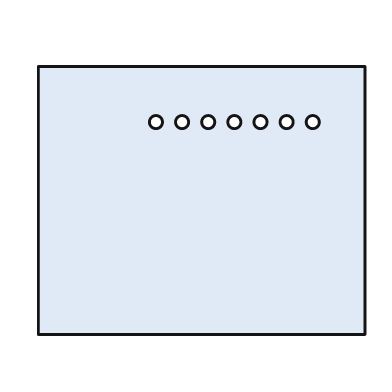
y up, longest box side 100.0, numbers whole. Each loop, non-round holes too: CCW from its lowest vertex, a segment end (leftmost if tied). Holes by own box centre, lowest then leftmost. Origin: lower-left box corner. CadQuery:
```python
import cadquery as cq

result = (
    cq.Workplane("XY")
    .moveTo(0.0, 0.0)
    .lineTo(100.0, 0.0)
    .lineTo(100.0, 82.0)
    .lineTo(0.0, 82.0)
    .close()
    .moveTo(36.0, 65.0)
    .circle(2.0)
    .moveTo(44.0, 65.0)
    .circle(2.0)
    .moveTo(52.0, 65.0)
    .circle(2.0)
    .moveTo(60.0, 65.0)
    .circle(2.0)
    .moveTo(68.0, 65.0)
    .circle(2.0)
    .moveTo(76.0, 65.0)
    .circle(2.0)
    .moveTo(84.0, 65.0)
    .circle(2.0)
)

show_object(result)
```